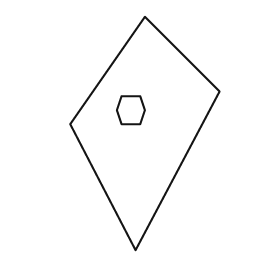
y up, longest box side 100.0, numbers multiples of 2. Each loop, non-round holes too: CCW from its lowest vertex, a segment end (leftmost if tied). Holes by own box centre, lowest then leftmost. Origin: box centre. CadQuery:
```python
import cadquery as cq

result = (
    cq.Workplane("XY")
    .moveTo(-4.0, -50.0)
    .lineTo(32.0, 18.0)
    .lineTo(0.0, 50.0)
    .lineTo(-32.0, 4.0)
    .close()
    .moveTo(-10.0, 4.0)
    .lineTo(-2.0, 4.0)
    .lineTo(0.0, 10.0)
    .lineTo(-2.0, 16.0)
    .lineTo(-10.0, 16.0)
    .lineTo(-12.0, 10.0)
    .close()
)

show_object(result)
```